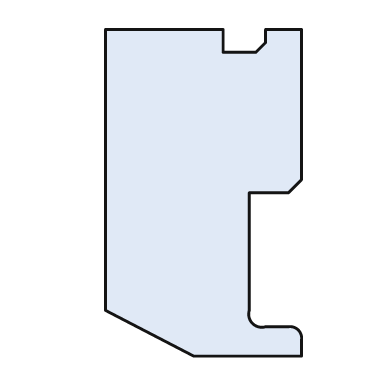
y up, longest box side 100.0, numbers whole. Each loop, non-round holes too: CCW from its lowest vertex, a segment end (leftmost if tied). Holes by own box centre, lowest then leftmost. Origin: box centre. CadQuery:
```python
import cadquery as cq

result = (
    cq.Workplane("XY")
    .moveTo(-3.0, -50.0)
    .lineTo(30.0, -50.0)
    .lineTo(30.0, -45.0)
    .threePointArc((29.0, -42.0), (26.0, -41.0))
    .lineTo(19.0, -41.0)
    .threePointArc((15.0, -40.0), (14.0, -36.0))
    .lineTo(14.0, 0.0)
    .lineTo(26.0, 0.0)
    .lineTo(30.0, 4.0)
    .lineTo(30.0, 50.0)
    .lineTo(19.0, 50.0)
    .lineTo(19.0, 46.0)
    .lineTo(16.0, 43.0)
    .lineTo(6.0, 43.0)
    .lineTo(6.0, 50.0)
    .lineTo(-30.0, 50.0)
    .lineTo(-30.0, -36.0)
    .close()
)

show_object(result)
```